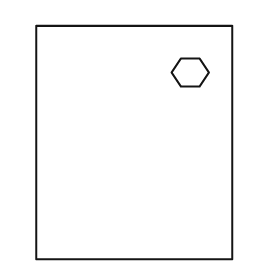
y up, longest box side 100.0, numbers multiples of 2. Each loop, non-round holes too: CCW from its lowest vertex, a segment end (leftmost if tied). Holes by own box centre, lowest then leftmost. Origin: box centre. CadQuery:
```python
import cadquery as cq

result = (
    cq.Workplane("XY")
    .moveTo(-42.0, -50.0)
    .lineTo(42.0, -50.0)
    .lineTo(42.0, 50.0)
    .lineTo(-42.0, 50.0)
    .close()
    .moveTo(20.0, 24.0)
    .lineTo(28.0, 24.0)
    .lineTo(32.0, 30.0)
    .lineTo(28.0, 36.0)
    .lineTo(20.0, 36.0)
    .lineTo(16.0, 30.0)
    .close()
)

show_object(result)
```